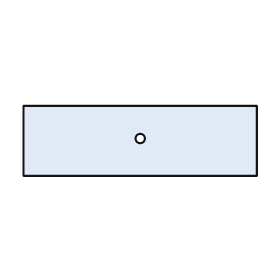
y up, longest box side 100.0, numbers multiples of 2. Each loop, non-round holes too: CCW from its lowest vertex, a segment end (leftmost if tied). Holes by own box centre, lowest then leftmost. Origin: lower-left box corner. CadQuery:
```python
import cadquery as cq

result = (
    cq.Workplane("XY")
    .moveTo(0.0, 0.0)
    .lineTo(100.0, 0.0)
    .lineTo(100.0, 30.0)
    .lineTo(0.0, 30.0)
    .close()
    .moveTo(50.0, 16.0)
    .circle(2.0)
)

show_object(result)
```